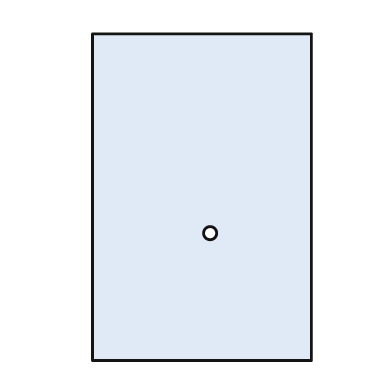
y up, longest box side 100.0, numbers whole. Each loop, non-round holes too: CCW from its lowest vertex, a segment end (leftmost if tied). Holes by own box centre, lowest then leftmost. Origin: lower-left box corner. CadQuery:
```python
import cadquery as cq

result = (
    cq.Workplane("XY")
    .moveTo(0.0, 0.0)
    .lineTo(67.0, 0.0)
    .lineTo(67.0, 100.0)
    .lineTo(0.0, 100.0)
    .close()
    .moveTo(36.0, 39.0)
    .circle(2.0)
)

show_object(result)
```